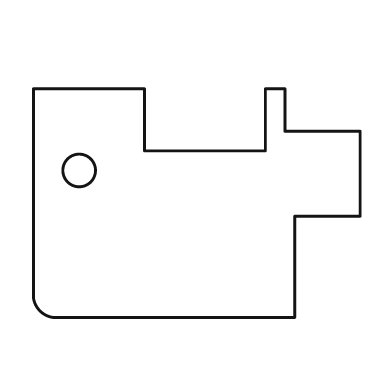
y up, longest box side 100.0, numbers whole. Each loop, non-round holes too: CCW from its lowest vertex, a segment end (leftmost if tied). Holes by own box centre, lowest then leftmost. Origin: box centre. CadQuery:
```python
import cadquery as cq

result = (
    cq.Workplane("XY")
    .moveTo(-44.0, -35.0)
    .lineTo(30.0, -35.0)
    .lineTo(30.0, -4.0)
    .lineTo(50.0, -4.0)
    .lineTo(50.0, 22.0)
    .lineTo(27.0, 22.0)
    .lineTo(27.0, 35.0)
    .lineTo(21.0, 35.0)
    .lineTo(21.0, 16.0)
    .lineTo(-16.0, 16.0)
    .lineTo(-16.0, 35.0)
    .lineTo(-50.0, 35.0)
    .lineTo(-50.0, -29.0)
    .threePointArc((-48.0, -33.0), (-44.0, -35.0))
    .close()
    .moveTo(-36.0, 10.0)
    .circle(5.0)
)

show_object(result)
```